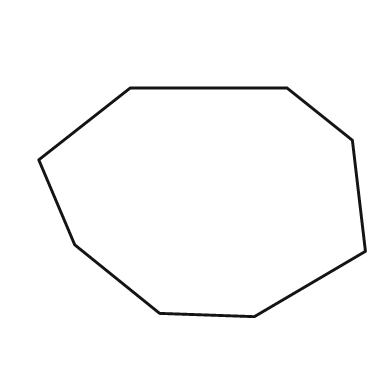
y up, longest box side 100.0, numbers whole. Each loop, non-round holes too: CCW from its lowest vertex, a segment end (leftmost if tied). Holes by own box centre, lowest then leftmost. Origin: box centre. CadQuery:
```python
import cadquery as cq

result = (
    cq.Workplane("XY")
    .moveTo(16.0, -35.0)
    .lineTo(50.0, -15.0)
    .lineTo(46.0, 19.0)
    .lineTo(26.0, 35.0)
    .lineTo(-22.0, 35.0)
    .lineTo(-50.0, 13.0)
    .lineTo(-39.0, -13.0)
    .lineTo(-13.0, -34.0)
    .close()
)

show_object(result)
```